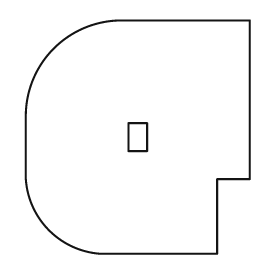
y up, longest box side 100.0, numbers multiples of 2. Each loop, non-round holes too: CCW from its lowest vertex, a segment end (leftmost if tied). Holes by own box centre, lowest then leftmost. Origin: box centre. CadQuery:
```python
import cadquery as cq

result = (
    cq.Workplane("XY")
    .moveTo(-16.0, -50.0)
    .lineTo(34.0, -50.0)
    .lineTo(34.0, -18.0)
    .lineTo(48.0, -18.0)
    .lineTo(48.0, 50.0)
    .lineTo(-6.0, 50.0)
    .threePointArc((-36.0, 38.0), (-48.0, 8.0))
    .lineTo(-48.0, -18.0)
    .threePointArc((-38.0, -40.0), (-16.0, -50.0))
    .close()
    .moveTo(-4.0, -6.0)
    .lineTo(4.0, -6.0)
    .lineTo(4.0, 6.0)
    .lineTo(-4.0, 6.0)
    .close()
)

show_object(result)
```